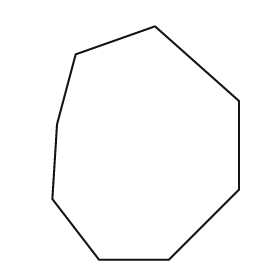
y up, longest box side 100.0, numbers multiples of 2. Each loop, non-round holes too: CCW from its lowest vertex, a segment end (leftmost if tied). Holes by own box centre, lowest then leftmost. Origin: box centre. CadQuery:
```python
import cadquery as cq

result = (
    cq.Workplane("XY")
    .moveTo(-20.0, -50.0)
    .lineTo(10.0, -50.0)
    .lineTo(40.0, -20.0)
    .lineTo(40.0, 18.0)
    .lineTo(4.0, 50.0)
    .lineTo(-30.0, 38.0)
    .lineTo(-38.0, 8.0)
    .lineTo(-40.0, -24.0)
    .close()
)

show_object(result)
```